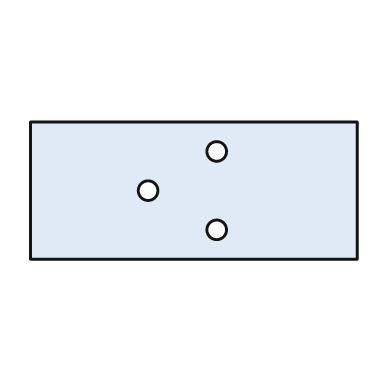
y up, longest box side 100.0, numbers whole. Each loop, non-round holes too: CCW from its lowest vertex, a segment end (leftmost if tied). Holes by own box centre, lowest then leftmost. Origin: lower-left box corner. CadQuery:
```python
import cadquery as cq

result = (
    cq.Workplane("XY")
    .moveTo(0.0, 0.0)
    .lineTo(100.0, 0.0)
    .lineTo(100.0, 42.0)
    .lineTo(0.0, 42.0)
    .close()
    .moveTo(57.0, 9.0)
    .circle(3.0)
    .moveTo(36.0, 21.0)
    .circle(3.0)
    .moveTo(57.0, 33.0)
    .circle(3.0)
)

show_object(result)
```